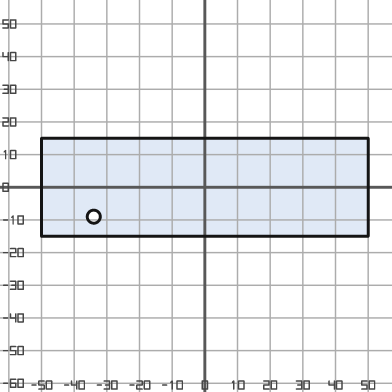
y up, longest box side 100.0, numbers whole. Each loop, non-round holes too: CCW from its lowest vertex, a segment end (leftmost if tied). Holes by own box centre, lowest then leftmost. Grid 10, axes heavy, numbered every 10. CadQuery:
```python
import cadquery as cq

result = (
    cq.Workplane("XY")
    .moveTo(-50.0, -15.0)
    .lineTo(50.0, -15.0)
    .lineTo(50.0, 15.0)
    .lineTo(-50.0, 15.0)
    .close()
    .moveTo(-34.0, -9.0)
    .circle(2.0)
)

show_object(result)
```